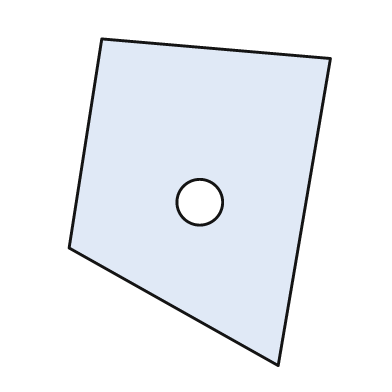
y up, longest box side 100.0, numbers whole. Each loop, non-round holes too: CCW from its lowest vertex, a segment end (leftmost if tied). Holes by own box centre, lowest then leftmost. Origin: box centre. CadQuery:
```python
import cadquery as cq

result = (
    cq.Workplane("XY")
    .moveTo(24.0, -50.0)
    .lineTo(40.0, 44.0)
    .lineTo(-30.0, 50.0)
    .lineTo(-40.0, -14.0)
    .close()
    .moveTo(0.0, 0.0)
    .circle(7.0)
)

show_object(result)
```